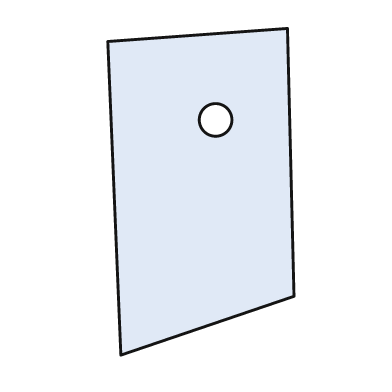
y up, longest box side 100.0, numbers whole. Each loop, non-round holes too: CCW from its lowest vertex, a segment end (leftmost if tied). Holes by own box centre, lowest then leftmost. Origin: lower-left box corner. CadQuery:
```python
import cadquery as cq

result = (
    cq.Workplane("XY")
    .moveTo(4.0, 0.0)
    .lineTo(57.0, 18.0)
    .lineTo(55.0, 100.0)
    .lineTo(0.0, 96.0)
    .close()
    .moveTo(33.0, 72.0)
    .circle(5.0)
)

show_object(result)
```